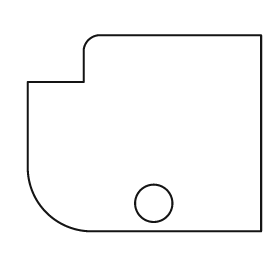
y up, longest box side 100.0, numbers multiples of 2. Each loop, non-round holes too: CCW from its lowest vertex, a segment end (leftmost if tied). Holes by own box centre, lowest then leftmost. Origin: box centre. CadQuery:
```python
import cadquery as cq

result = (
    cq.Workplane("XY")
    .moveTo(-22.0, -42.0)
    .lineTo(50.0, -42.0)
    .lineTo(50.0, 42.0)
    .lineTo(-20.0, 42.0)
    .threePointArc((-24.0, 40.0), (-26.0, 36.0))
    .lineTo(-26.0, 22.0)
    .lineTo(-50.0, 22.0)
    .lineTo(-50.0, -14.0)
    .threePointArc((-42.0, -34.0), (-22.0, -42.0))
    .close()
    .moveTo(4.0, -30.0)
    .circle(8.0)
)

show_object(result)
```